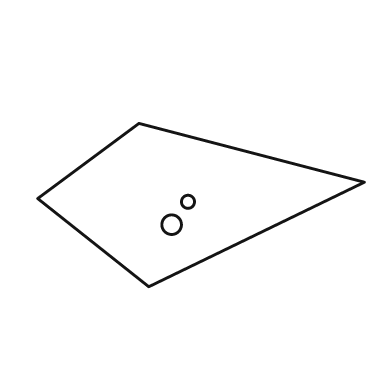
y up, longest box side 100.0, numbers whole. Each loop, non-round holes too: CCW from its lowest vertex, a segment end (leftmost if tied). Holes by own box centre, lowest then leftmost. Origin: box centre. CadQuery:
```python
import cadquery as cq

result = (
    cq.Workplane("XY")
    .moveTo(-16.0, -25.0)
    .lineTo(50.0, 7.0)
    .lineTo(-19.0, 25.0)
    .lineTo(-50.0, 2.0)
    .close()
    .moveTo(-9.0, -6.0)
    .circle(3.0)
    .moveTo(-4.0, 1.0)
    .circle(2.0)
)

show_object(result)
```